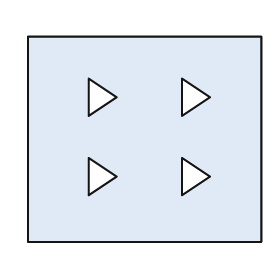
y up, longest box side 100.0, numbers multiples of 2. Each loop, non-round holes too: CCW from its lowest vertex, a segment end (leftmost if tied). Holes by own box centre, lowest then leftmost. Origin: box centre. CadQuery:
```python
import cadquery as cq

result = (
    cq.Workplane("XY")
    .moveTo(-50.0, -44.0)
    .lineTo(50.0, -44.0)
    .lineTo(50.0, 44.0)
    .lineTo(-50.0, 44.0)
    .close()
    .moveTo(-24.0, -24.0)
    .lineTo(-12.0, -16.0)
    .lineTo(-24.0, -8.0)
    .close()
    .moveTo(16.0, -24.0)
    .lineTo(28.0, -16.0)
    .lineTo(16.0, -8.0)
    .close()
    .moveTo(-24.0, 10.0)
    .lineTo(-12.0, 18.0)
    .lineTo(-24.0, 26.0)
    .close()
    .moveTo(16.0, 10.0)
    .lineTo(28.0, 18.0)
    .lineTo(16.0, 26.0)
    .close()
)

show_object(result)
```